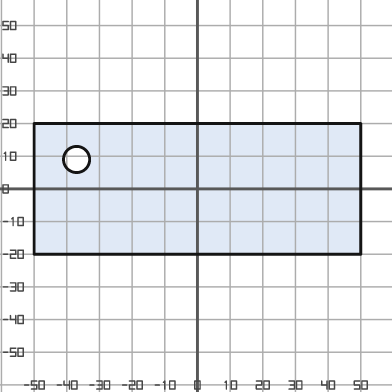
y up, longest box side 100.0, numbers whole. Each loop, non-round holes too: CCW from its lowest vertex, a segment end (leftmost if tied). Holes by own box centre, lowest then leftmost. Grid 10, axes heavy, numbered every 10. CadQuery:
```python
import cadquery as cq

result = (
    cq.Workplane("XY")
    .moveTo(-50.0, -20.0)
    .lineTo(50.0, -20.0)
    .lineTo(50.0, 20.0)
    .lineTo(-50.0, 20.0)
    .close()
    .moveTo(-37.0, 9.0)
    .circle(4.0)
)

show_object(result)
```